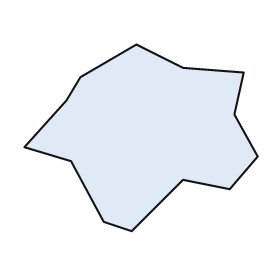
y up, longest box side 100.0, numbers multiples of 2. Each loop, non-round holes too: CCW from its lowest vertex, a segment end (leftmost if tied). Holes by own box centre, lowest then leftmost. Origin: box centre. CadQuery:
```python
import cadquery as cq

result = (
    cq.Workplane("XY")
    .moveTo(-4.0, -40.0)
    .lineTo(18.0, -18.0)
    .lineTo(38.0, -22.0)
    .lineTo(50.0, -8.0)
    .lineTo(40.0, 10.0)
    .lineTo(44.0, 28.0)
    .lineTo(18.0, 30.0)
    .lineTo(-2.0, 40.0)
    .lineTo(-26.0, 26.0)
    .lineTo(-32.0, 16.0)
    .lineTo(-50.0, -4.0)
    .lineTo(-30.0, -10.0)
    .lineTo(-16.0, -36.0)
    .close()
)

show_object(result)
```